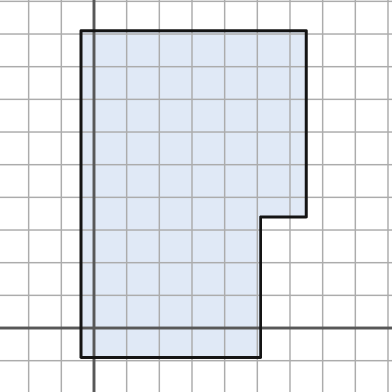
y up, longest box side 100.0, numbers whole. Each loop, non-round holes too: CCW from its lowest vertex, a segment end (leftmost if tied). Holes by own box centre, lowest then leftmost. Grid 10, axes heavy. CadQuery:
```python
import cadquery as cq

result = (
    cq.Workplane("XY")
    .moveTo(-4.0, -9.0)
    .lineTo(51.0, -9.0)
    .lineTo(51.0, 34.0)
    .lineTo(65.0, 34.0)
    .lineTo(65.0, 91.0)
    .lineTo(-4.0, 91.0)
    .close()
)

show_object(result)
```